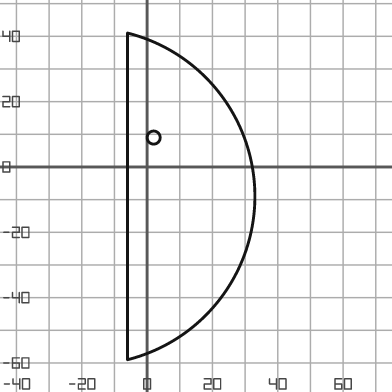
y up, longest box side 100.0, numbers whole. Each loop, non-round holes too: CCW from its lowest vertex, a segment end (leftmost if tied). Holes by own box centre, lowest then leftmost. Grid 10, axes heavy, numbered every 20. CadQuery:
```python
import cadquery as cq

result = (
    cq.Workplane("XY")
    .moveTo(-6.0, -59.0)
    .threePointArc((33.0, -9.0), (-6.0, 41.0))
    .close()
    .moveTo(2.0, 9.0)
    .circle(2.0)
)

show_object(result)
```